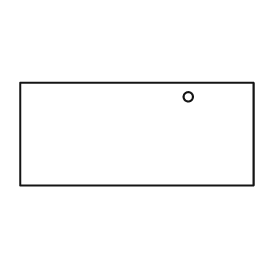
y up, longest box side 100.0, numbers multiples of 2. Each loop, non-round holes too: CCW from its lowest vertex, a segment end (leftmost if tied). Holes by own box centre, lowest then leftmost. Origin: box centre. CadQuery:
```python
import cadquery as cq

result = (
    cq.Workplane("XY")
    .moveTo(-50.0, -22.0)
    .lineTo(50.0, -22.0)
    .lineTo(50.0, 22.0)
    .lineTo(-50.0, 22.0)
    .close()
    .moveTo(22.0, 16.0)
    .circle(2.0)
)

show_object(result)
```